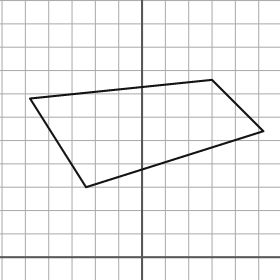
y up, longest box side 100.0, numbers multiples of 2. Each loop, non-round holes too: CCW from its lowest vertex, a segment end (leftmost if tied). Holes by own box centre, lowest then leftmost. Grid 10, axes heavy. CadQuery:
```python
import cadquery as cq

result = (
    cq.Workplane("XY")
    .moveTo(-24.0, 30.0)
    .lineTo(52.0, 54.0)
    .lineTo(30.0, 76.0)
    .lineTo(-48.0, 68.0)
    .close()
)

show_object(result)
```